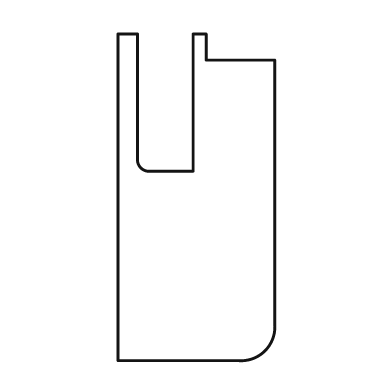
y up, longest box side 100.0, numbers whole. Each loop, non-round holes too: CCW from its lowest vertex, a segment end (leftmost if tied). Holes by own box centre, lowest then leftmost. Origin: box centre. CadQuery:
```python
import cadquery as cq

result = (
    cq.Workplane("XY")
    .moveTo(-24.0, -50.0)
    .lineTo(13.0, -50.0)
    .threePointArc((21.0, -47.0), (24.0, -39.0))
    .lineTo(24.0, 42.0)
    .lineTo(3.0, 42.0)
    .lineTo(3.0, 50.0)
    .lineTo(-1.0, 50.0)
    .lineTo(-1.0, 8.0)
    .lineTo(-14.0, 8.0)
    .threePointArc((-17.0, 9.0), (-18.0, 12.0))
    .lineTo(-18.0, 50.0)
    .lineTo(-24.0, 50.0)
    .close()
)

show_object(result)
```